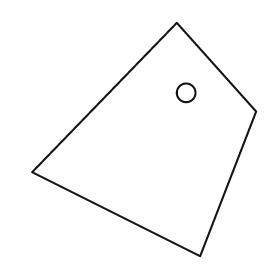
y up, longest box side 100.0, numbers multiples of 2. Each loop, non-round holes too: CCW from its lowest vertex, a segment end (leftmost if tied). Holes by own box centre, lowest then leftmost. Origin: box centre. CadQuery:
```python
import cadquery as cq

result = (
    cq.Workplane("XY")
    .moveTo(24.0, -50.0)
    .lineTo(48.0, 12.0)
    .lineTo(14.0, 50.0)
    .lineTo(-48.0, -14.0)
    .close()
    .moveTo(18.0, 20.0)
    .circle(4.0)
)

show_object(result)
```